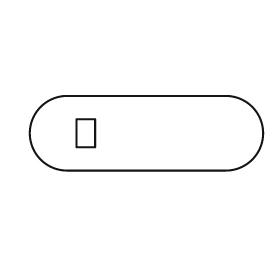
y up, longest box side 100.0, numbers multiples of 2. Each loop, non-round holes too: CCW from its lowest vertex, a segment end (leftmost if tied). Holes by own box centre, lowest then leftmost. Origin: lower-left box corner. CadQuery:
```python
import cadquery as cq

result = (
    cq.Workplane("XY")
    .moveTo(16.0, 0.0)
    .lineTo(84.0, 0.0)
    .threePointArc((100.0, 16.0), (84.0, 32.0))
    .lineTo(16.0, 32.0)
    .threePointArc((0.0, 16.0), (16.0, 0.0))
    .close()
    .moveTo(20.0, 10.0)
    .lineTo(28.0, 10.0)
    .lineTo(28.0, 22.0)
    .lineTo(20.0, 22.0)
    .close()
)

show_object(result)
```